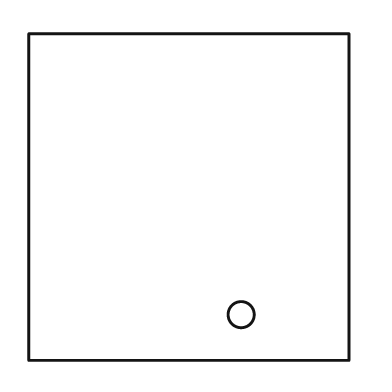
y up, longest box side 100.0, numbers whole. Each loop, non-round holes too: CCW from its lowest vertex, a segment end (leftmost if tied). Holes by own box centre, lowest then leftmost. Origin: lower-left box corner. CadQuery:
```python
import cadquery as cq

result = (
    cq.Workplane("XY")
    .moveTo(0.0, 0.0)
    .lineTo(98.0, 0.0)
    .lineTo(98.0, 100.0)
    .lineTo(0.0, 100.0)
    .close()
    .moveTo(65.0, 14.0)
    .circle(4.0)
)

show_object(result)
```